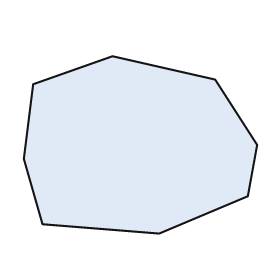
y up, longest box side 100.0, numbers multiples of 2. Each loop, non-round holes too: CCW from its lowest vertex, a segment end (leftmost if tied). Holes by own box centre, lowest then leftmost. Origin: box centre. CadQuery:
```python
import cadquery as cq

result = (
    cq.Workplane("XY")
    .moveTo(8.0, -38.0)
    .lineTo(46.0, -22.0)
    .lineTo(50.0, 0.0)
    .lineTo(32.0, 28.0)
    .lineTo(-12.0, 38.0)
    .lineTo(-46.0, 26.0)
    .lineTo(-50.0, -6.0)
    .lineTo(-42.0, -34.0)
    .close()
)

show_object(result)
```